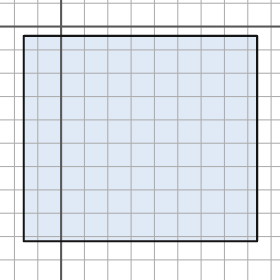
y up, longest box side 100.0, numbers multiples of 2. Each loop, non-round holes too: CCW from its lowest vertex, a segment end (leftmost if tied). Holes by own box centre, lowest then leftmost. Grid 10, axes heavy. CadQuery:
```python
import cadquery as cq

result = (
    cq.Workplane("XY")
    .moveTo(-16.0, -92.0)
    .lineTo(84.0, -92.0)
    .lineTo(84.0, -4.0)
    .lineTo(-16.0, -4.0)
    .close()
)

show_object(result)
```